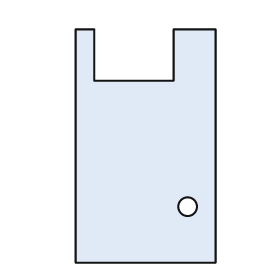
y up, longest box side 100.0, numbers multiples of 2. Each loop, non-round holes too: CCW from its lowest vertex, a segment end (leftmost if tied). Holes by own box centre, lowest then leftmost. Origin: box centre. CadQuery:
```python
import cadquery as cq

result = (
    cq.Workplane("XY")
    .moveTo(-30.0, -50.0)
    .lineTo(30.0, -50.0)
    .lineTo(30.0, 50.0)
    .lineTo(12.0, 50.0)
    .lineTo(12.0, 28.0)
    .lineTo(-22.0, 28.0)
    .lineTo(-22.0, 50.0)
    .lineTo(-30.0, 50.0)
    .close()
    .moveTo(18.0, -26.0)
    .circle(4.0)
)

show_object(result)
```